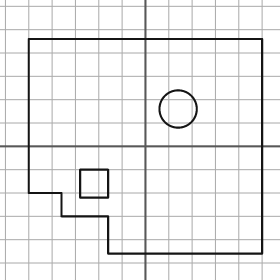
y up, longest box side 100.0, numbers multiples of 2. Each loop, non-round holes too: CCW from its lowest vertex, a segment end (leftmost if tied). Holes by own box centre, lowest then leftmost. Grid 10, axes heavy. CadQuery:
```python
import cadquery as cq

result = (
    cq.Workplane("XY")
    .moveTo(-16.0, -46.0)
    .lineTo(50.0, -46.0)
    .lineTo(50.0, 46.0)
    .lineTo(-50.0, 46.0)
    .lineTo(-50.0, -20.0)
    .lineTo(-36.0, -20.0)
    .lineTo(-36.0, -30.0)
    .lineTo(-16.0, -30.0)
    .close()
    .moveTo(-28.0, -22.0)
    .lineTo(-16.0, -22.0)
    .lineTo(-16.0, -10.0)
    .lineTo(-28.0, -10.0)
    .close()
    .moveTo(14.0, 16.0)
    .circle(8.0)
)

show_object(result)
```